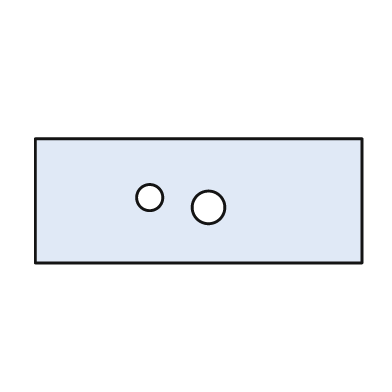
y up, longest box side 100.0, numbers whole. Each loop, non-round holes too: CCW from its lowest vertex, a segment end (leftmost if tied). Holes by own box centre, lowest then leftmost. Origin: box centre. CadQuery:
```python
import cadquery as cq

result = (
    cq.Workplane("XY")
    .moveTo(-50.0, -19.0)
    .lineTo(50.0, -19.0)
    .lineTo(50.0, 19.0)
    .lineTo(-50.0, 19.0)
    .close()
    .moveTo(3.0, -2.0)
    .circle(5.0)
    .moveTo(-15.0, 1.0)
    .circle(4.0)
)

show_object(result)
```